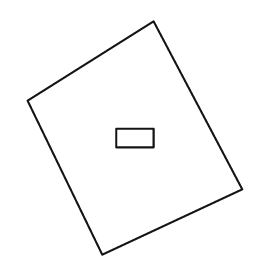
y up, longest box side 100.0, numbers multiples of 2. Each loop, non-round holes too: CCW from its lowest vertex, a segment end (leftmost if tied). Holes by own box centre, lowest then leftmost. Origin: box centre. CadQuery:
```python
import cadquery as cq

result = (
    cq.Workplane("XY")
    .moveTo(-14.0, -50.0)
    .lineTo(46.0, -22.0)
    .lineTo(8.0, 50.0)
    .lineTo(-46.0, 16.0)
    .close()
    .moveTo(-8.0, -4.0)
    .lineTo(8.0, -4.0)
    .lineTo(8.0, 4.0)
    .lineTo(-8.0, 4.0)
    .close()
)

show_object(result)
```